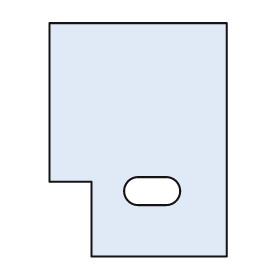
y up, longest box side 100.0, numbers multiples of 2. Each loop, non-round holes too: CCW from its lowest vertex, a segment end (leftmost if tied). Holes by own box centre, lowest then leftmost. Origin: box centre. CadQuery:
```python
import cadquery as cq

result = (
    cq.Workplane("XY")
    .moveTo(-20.0, -50.0)
    .lineTo(38.0, -50.0)
    .lineTo(38.0, 50.0)
    .lineTo(-38.0, 50.0)
    .lineTo(-38.0, -18.0)
    .lineTo(-20.0, -18.0)
    .close()
    .moveTo(0.0, -28.0)
    .lineTo(12.0, -28.0)
    .threePointArc((18.0, -22.0), (12.0, -16.0))
    .lineTo(0.0, -16.0)
    .threePointArc((-6.0, -22.0), (0.0, -28.0))
    .close()
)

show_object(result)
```